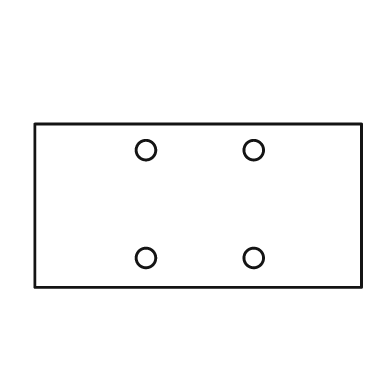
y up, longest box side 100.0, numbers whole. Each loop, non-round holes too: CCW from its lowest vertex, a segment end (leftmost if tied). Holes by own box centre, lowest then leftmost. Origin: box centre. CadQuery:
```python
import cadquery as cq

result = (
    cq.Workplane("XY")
    .moveTo(-50.0, -25.0)
    .lineTo(50.0, -25.0)
    .lineTo(50.0, 25.0)
    .lineTo(-50.0, 25.0)
    .close()
    .moveTo(-16.0, -16.0)
    .circle(3.0)
    .moveTo(17.0, -16.0)
    .circle(3.0)
    .moveTo(-16.0, 17.0)
    .circle(3.0)
    .moveTo(17.0, 17.0)
    .circle(3.0)
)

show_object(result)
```